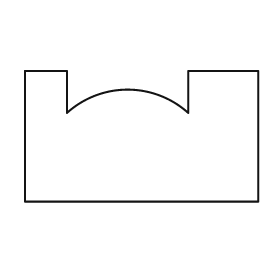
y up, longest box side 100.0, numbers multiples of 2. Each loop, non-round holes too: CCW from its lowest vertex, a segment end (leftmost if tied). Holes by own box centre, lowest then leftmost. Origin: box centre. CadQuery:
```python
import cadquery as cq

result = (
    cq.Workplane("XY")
    .moveTo(-50.0, -28.0)
    .lineTo(50.0, -28.0)
    .lineTo(50.0, 28.0)
    .lineTo(20.0, 28.0)
    .lineTo(20.0, 10.0)
    .threePointArc((-6.0, 20.0), (-32.0, 10.0))
    .lineTo(-32.0, 28.0)
    .lineTo(-50.0, 28.0)
    .close()
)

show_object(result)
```